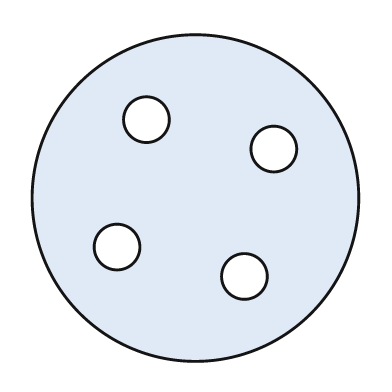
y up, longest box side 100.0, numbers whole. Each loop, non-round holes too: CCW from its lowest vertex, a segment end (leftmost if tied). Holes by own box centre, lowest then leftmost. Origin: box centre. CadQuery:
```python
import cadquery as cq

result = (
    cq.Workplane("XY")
    .moveTo(0.0, 0.0)
    .circle(50.0)
    .moveTo(15.0, -24.0)
    .circle(7.0)
    .moveTo(-24.0, -15.0)
    .circle(7.0)
    .moveTo(24.0, 15.0)
    .circle(7.0)
    .moveTo(-15.0, 24.0)
    .circle(7.0)
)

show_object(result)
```